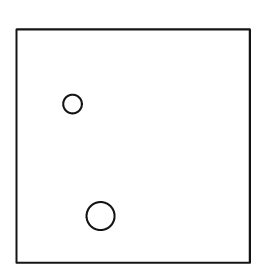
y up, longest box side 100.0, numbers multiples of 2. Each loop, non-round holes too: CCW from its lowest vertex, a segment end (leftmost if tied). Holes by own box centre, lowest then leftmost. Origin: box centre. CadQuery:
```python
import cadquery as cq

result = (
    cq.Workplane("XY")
    .moveTo(-50.0, -50.0)
    .lineTo(50.0, -50.0)
    .lineTo(50.0, 50.0)
    .lineTo(-50.0, 50.0)
    .close()
    .moveTo(-14.0, -30.0)
    .circle(6.0)
    .moveTo(-26.0, 18.0)
    .circle(4.0)
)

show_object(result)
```